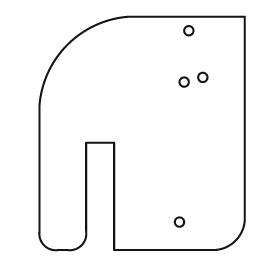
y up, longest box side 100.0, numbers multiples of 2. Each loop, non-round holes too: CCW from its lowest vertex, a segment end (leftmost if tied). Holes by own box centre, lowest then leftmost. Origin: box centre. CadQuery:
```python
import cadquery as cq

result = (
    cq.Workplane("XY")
    .moveTo(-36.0, -50.0)
    .lineTo(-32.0, -50.0)
    .threePointArc((-26.0, -48.0), (-24.0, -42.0))
    .lineTo(-24.0, -4.0)
    .lineTo(-12.0, -4.0)
    .lineTo(-12.0, -50.0)
    .lineTo(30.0, -50.0)
    .threePointArc((40.0, -46.0), (44.0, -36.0))
    .lineTo(44.0, 50.0)
    .lineTo(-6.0, 50.0)
    .threePointArc((-32.0, 38.0), (-44.0, 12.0))
    .lineTo(-44.0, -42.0)
    .threePointArc((-42.0, -48.0), (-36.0, -50.0))
    .close()
    .moveTo(16.0, -38.0)
    .circle(2.0)
    .moveTo(18.0, 22.0)
    .circle(2.0)
    .moveTo(26.0, 24.0)
    .circle(2.0)
    .moveTo(20.0, 44.0)
    .circle(2.0)
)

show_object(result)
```